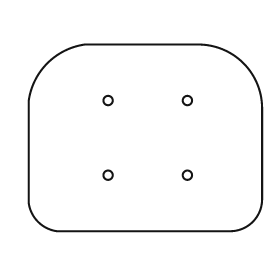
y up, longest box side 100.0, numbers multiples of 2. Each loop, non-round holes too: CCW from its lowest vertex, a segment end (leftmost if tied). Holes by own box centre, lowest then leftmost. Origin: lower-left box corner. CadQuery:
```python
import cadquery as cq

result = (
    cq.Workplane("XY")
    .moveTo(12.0, 0.0)
    .lineTo(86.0, 0.0)
    .threePointArc((96.0, 4.0), (100.0, 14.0))
    .lineTo(100.0, 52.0)
    .threePointArc((92.0, 72.0), (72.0, 80.0))
    .lineTo(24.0, 80.0)
    .threePointArc((8.0, 72.0), (0.0, 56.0))
    .lineTo(0.0, 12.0)
    .threePointArc((4.0, 4.0), (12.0, 0.0))
    .close()
    .moveTo(34.0, 24.0)
    .circle(2.0)
    .moveTo(68.0, 24.0)
    .circle(2.0)
    .moveTo(34.0, 56.0)
    .circle(2.0)
    .moveTo(68.0, 56.0)
    .circle(2.0)
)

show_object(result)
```